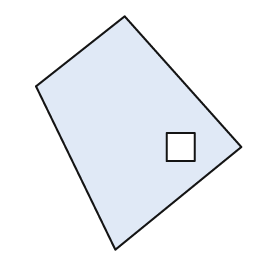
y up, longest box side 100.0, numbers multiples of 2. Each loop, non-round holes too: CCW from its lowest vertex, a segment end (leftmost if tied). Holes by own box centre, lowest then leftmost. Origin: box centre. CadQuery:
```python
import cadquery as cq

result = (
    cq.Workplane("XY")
    .moveTo(-10.0, -50.0)
    .lineTo(44.0, -6.0)
    .lineTo(-6.0, 50.0)
    .lineTo(-44.0, 20.0)
    .close()
    .moveTo(12.0, -12.0)
    .lineTo(24.0, -12.0)
    .lineTo(24.0, 0.0)
    .lineTo(12.0, 0.0)
    .close()
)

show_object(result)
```